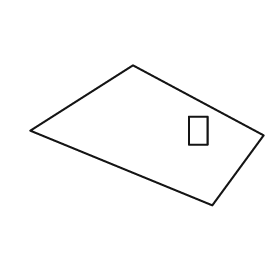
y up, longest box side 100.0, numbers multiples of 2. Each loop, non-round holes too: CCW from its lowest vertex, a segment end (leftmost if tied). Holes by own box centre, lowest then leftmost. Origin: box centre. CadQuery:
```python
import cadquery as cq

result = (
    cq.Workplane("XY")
    .moveTo(28.0, -30.0)
    .lineTo(50.0, 0.0)
    .lineTo(-6.0, 30.0)
    .lineTo(-50.0, 2.0)
    .close()
    .moveTo(18.0, -4.0)
    .lineTo(26.0, -4.0)
    .lineTo(26.0, 8.0)
    .lineTo(18.0, 8.0)
    .close()
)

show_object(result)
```